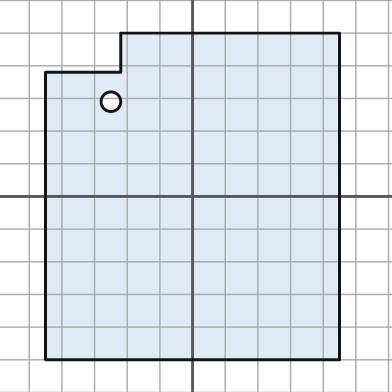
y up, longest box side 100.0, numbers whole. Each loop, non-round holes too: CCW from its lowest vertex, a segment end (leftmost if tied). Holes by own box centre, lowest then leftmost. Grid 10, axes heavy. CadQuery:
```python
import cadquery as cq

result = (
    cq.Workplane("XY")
    .moveTo(-45.0, -50.0)
    .lineTo(45.0, -50.0)
    .lineTo(45.0, 50.0)
    .lineTo(-22.0, 50.0)
    .lineTo(-22.0, 38.0)
    .lineTo(-45.0, 38.0)
    .close()
    .moveTo(-25.0, 29.0)
    .circle(3.0)
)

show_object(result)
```